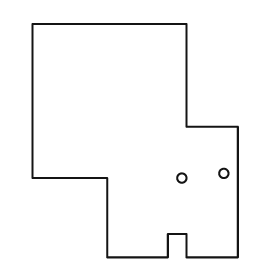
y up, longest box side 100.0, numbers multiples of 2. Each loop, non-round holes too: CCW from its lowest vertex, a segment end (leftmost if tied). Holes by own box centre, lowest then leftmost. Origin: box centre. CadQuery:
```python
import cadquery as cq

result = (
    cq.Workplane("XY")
    .moveTo(-12.0, -50.0)
    .lineTo(14.0, -50.0)
    .lineTo(14.0, -40.0)
    .lineTo(22.0, -40.0)
    .lineTo(22.0, -50.0)
    .lineTo(44.0, -50.0)
    .lineTo(44.0, 6.0)
    .lineTo(22.0, 6.0)
    .lineTo(22.0, 50.0)
    .lineTo(-44.0, 50.0)
    .lineTo(-44.0, -16.0)
    .lineTo(-12.0, -16.0)
    .close()
    .moveTo(20.0, -16.0)
    .circle(2.0)
    .moveTo(38.0, -14.0)
    .circle(2.0)
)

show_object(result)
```